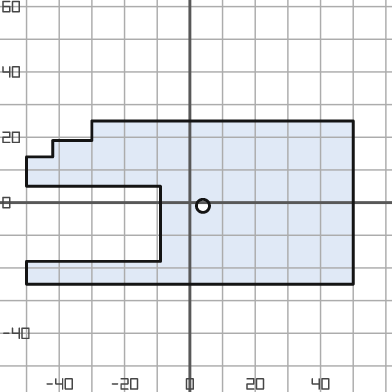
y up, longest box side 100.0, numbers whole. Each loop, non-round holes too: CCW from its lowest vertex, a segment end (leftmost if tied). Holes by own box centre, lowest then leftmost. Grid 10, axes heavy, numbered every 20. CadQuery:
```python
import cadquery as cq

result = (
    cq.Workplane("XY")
    .moveTo(-50.0, -25.0)
    .lineTo(50.0, -25.0)
    .lineTo(50.0, 25.0)
    .lineTo(-30.0, 25.0)
    .lineTo(-30.0, 19.0)
    .lineTo(-42.0, 19.0)
    .lineTo(-42.0, 14.0)
    .lineTo(-50.0, 14.0)
    .lineTo(-50.0, 5.0)
    .lineTo(-9.0, 5.0)
    .lineTo(-9.0, -18.0)
    .lineTo(-50.0, -18.0)
    .close()
    .moveTo(4.0, -1.0)
    .circle(2.0)
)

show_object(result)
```